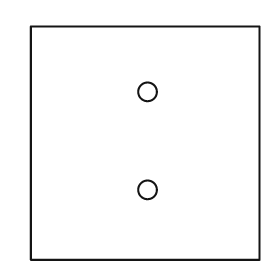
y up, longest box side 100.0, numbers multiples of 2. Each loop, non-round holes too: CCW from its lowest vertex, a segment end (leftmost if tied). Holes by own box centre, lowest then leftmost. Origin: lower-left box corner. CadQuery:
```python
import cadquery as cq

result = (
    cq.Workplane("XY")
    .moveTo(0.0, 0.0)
    .lineTo(98.0, 0.0)
    .lineTo(98.0, 100.0)
    .lineTo(0.0, 100.0)
    .close()
    .moveTo(50.0, 30.0)
    .circle(4.0)
    .moveTo(50.0, 72.0)
    .circle(4.0)
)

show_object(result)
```